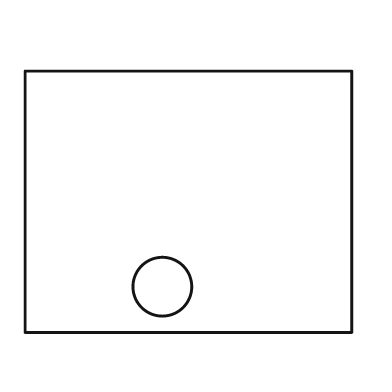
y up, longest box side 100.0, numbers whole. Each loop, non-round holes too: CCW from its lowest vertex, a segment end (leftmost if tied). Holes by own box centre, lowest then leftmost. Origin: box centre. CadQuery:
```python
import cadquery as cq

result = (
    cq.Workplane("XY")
    .moveTo(-50.0, -40.0)
    .lineTo(50.0, -40.0)
    .lineTo(50.0, 40.0)
    .lineTo(-50.0, 40.0)
    .close()
    .moveTo(-8.0, -26.0)
    .circle(9.0)
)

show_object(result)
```